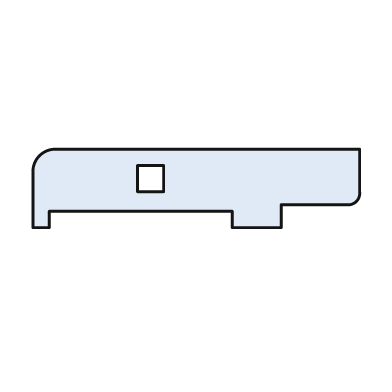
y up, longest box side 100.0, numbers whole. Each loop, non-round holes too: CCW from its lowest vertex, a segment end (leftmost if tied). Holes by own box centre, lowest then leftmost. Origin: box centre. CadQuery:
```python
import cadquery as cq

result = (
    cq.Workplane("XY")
    .moveTo(-50.0, -12.0)
    .lineTo(-45.0, -12.0)
    .lineTo(-45.0, -7.0)
    .lineTo(11.0, -7.0)
    .lineTo(11.0, -12.0)
    .lineTo(26.0, -12.0)
    .lineTo(26.0, -5.0)
    .lineTo(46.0, -5.0)
    .threePointArc((49.0, -4.0), (50.0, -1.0))
    .lineTo(50.0, 12.0)
    .lineTo(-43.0, 12.0)
    .threePointArc((-48.0, 10.0), (-50.0, 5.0))
    .close()
    .moveTo(-18.0, -1.0)
    .lineTo(-10.0, -1.0)
    .lineTo(-10.0, 7.0)
    .lineTo(-18.0, 7.0)
    .close()
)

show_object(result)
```